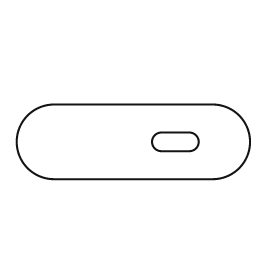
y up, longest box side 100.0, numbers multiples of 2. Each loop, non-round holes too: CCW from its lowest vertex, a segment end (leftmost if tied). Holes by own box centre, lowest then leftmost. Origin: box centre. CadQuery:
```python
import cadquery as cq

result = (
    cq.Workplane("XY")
    .moveTo(-34.0, -16.0)
    .lineTo(34.0, -16.0)
    .threePointArc((50.0, 0.0), (34.0, 16.0))
    .lineTo(-34.0, 16.0)
    .threePointArc((-50.0, 0.0), (-34.0, -16.0))
    .close()
    .moveTo(12.0, -4.0)
    .lineTo(24.0, -4.0)
    .threePointArc((28.0, 0.0), (24.0, 4.0))
    .lineTo(12.0, 4.0)
    .threePointArc((8.0, 0.0), (12.0, -4.0))
    .close()
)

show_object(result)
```